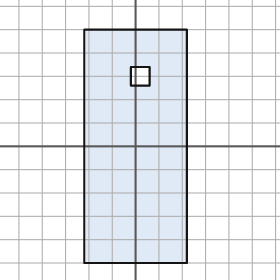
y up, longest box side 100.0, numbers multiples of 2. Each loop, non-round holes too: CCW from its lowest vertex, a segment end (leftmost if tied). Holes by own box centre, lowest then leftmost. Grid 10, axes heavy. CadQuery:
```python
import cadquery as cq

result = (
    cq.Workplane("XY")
    .moveTo(-22.0, -50.0)
    .lineTo(22.0, -50.0)
    .lineTo(22.0, 50.0)
    .lineTo(-22.0, 50.0)
    .close()
    .moveTo(-2.0, 26.0)
    .lineTo(6.0, 26.0)
    .lineTo(6.0, 34.0)
    .lineTo(-2.0, 34.0)
    .close()
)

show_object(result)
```